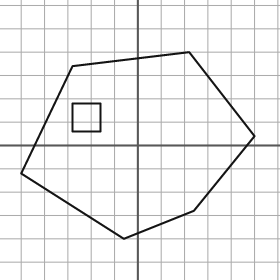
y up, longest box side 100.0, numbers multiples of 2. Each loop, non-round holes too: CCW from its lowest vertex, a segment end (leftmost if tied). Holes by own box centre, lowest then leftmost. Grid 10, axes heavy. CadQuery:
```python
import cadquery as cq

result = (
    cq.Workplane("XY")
    .moveTo(-6.0, -40.0)
    .lineTo(24.0, -28.0)
    .lineTo(50.0, 4.0)
    .lineTo(22.0, 40.0)
    .lineTo(-28.0, 34.0)
    .lineTo(-50.0, -12.0)
    .close()
    .moveTo(-28.0, 6.0)
    .lineTo(-16.0, 6.0)
    .lineTo(-16.0, 18.0)
    .lineTo(-28.0, 18.0)
    .close()
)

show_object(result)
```